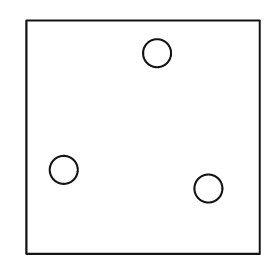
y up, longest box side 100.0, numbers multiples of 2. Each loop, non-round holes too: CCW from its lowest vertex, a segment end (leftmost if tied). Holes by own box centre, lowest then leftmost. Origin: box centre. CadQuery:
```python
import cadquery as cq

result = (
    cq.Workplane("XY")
    .moveTo(-50.0, -50.0)
    .lineTo(50.0, -50.0)
    .lineTo(50.0, 50.0)
    .lineTo(-50.0, 50.0)
    .close()
    .moveTo(28.0, -22.0)
    .circle(6.0)
    .moveTo(-34.0, -14.0)
    .circle(6.0)
    .moveTo(6.0, 36.0)
    .circle(6.0)
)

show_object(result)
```